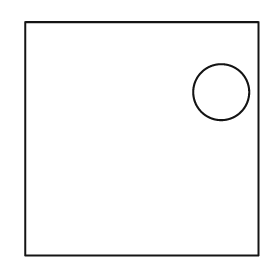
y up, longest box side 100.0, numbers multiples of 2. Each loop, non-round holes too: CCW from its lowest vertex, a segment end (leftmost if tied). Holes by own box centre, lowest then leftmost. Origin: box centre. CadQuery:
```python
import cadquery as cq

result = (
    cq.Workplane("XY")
    .moveTo(-50.0, -50.0)
    .lineTo(50.0, -50.0)
    .lineTo(50.0, 50.0)
    .lineTo(-50.0, 50.0)
    .close()
    .moveTo(34.0, 20.0)
    .circle(12.0)
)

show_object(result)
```